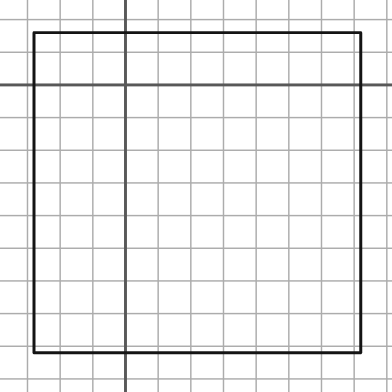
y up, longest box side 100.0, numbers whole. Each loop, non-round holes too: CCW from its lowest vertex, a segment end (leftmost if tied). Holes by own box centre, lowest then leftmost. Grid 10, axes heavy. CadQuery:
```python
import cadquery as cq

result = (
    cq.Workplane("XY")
    .moveTo(-28.0, -82.0)
    .lineTo(72.0, -82.0)
    .lineTo(72.0, 16.0)
    .lineTo(-28.0, 16.0)
    .close()
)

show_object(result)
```